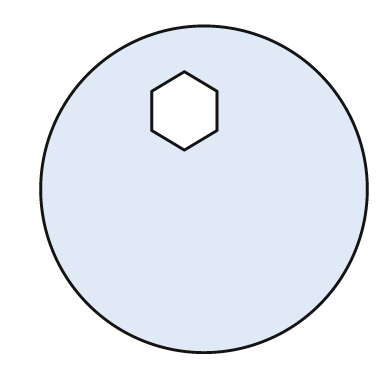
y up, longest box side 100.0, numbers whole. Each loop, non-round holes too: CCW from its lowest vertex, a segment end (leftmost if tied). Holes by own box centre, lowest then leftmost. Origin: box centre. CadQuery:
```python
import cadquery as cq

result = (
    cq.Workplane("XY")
    .moveTo(0.0, 0.0)
    .circle(50.0)
    .moveTo(-6.0, 12.0)
    .lineTo(4.0, 18.0)
    .lineTo(4.0, 30.0)
    .lineTo(-6.0, 36.0)
    .lineTo(-16.0, 30.0)
    .lineTo(-16.0, 18.0)
    .close()
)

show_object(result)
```